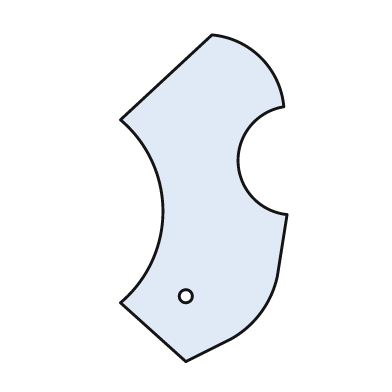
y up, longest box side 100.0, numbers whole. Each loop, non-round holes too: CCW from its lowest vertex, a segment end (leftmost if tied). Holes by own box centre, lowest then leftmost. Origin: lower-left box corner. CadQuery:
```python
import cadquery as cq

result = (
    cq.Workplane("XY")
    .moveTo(20.0, 0.0)
    .lineTo(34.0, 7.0)
    .threePointArc((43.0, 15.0), (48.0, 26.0))
    .lineTo(51.0, 45.0)
    .threePointArc((36.0, 61.0), (50.0, 78.0))
    .threePointArc((43.0, 93.0), (28.0, 100.0))
    .lineTo(0.0, 74.0)
    .threePointArc((13.0, 46.0), (0.0, 18.0))
    .close()
    .moveTo(20.0, 20.0)
    .circle(2.0)
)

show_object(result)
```